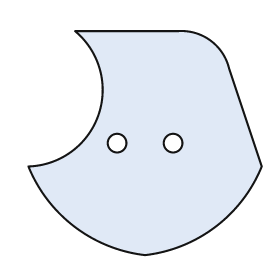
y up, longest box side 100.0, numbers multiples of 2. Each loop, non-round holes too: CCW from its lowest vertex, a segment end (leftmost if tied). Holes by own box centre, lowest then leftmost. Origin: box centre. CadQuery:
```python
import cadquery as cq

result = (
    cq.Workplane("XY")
    .moveTo(0.0, -48.0)
    .threePointArc((30.0, -36.0), (50.0, -10.0))
    .lineTo(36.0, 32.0)
    .threePointArc((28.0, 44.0), (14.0, 48.0))
    .lineTo(-30.0, 48.0)
    .threePointArc((-20.0, 12.0), (-50.0, -10.0))
    .threePointArc((-30.0, -36.0), (0.0, -48.0))
    .close()
    .moveTo(-12.0, 0.0)
    .circle(4.0)
    .moveTo(12.0, 0.0)
    .circle(4.0)
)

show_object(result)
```